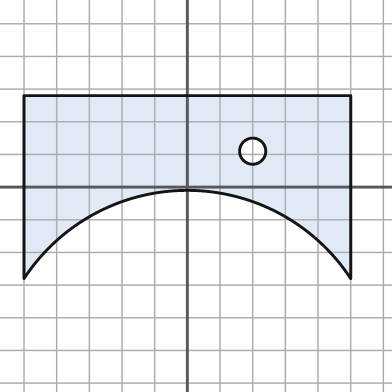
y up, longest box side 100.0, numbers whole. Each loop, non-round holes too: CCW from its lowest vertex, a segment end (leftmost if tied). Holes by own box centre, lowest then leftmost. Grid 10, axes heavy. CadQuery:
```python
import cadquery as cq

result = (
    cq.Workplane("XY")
    .moveTo(-50.0, -28.0)
    .threePointArc((0.0, -1.0), (50.0, -28.0))
    .lineTo(50.0, 28.0)
    .lineTo(-50.0, 28.0)
    .close()
    .moveTo(20.0, 11.0)
    .circle(4.0)
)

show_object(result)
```